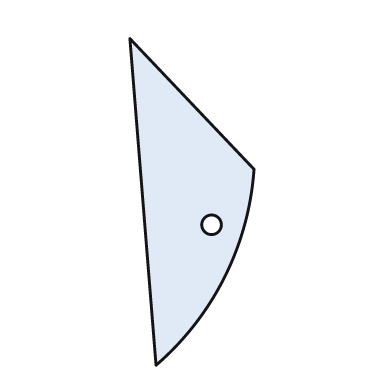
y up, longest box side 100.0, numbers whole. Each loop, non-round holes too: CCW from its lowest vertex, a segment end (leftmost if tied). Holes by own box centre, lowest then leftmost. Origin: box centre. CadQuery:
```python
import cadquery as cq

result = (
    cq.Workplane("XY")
    .moveTo(-11.0, -50.0)
    .threePointArc((10.0, -23.0), (19.0, 10.0))
    .lineTo(-19.0, 50.0)
    .close()
    .moveTo(6.0, -7.0)
    .circle(3.0)
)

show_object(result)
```